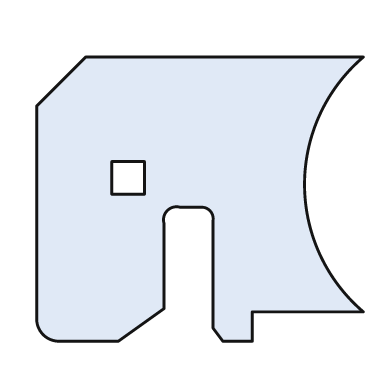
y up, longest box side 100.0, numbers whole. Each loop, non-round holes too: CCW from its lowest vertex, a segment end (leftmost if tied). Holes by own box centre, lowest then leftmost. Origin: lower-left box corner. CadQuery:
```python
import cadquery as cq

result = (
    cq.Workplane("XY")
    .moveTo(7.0, 0.0)
    .lineTo(25.0, 0.0)
    .lineTo(39.0, 10.0)
    .lineTo(39.0, 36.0)
    .threePointArc((40.0, 40.0), (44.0, 41.0))
    .lineTo(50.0, 41.0)
    .threePointArc((53.0, 40.0), (54.0, 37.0))
    .lineTo(54.0, 4.0)
    .lineTo(57.0, 0.0)
    .lineTo(66.0, 0.0)
    .lineTo(66.0, 9.0)
    .lineTo(100.0, 9.0)
    .threePointArc((82.0, 48.0), (100.0, 87.0))
    .lineTo(15.0, 87.0)
    .lineTo(0.0, 72.0)
    .lineTo(0.0, 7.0)
    .threePointArc((2.0, 2.0), (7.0, 0.0))
    .close()
    .moveTo(23.0, 45.0)
    .lineTo(33.0, 45.0)
    .lineTo(33.0, 55.0)
    .lineTo(23.0, 55.0)
    .close()
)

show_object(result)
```